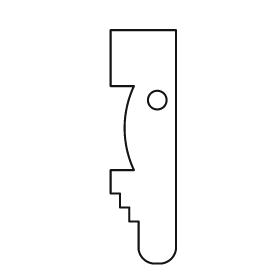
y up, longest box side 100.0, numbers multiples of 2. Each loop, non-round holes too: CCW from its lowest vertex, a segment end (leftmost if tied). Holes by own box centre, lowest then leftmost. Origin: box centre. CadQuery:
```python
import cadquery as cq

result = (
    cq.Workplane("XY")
    .moveTo(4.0, -50.0)
    .lineTo(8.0, -50.0)
    .threePointArc((12.0, -48.0), (14.0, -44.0))
    .lineTo(14.0, 50.0)
    .lineTo(-14.0, 50.0)
    .lineTo(-14.0, 26.0)
    .lineTo(-4.0, 26.0)
    .threePointArc((-8.0, 8.0), (-4.0, -10.0))
    .lineTo(-14.0, -10.0)
    .lineTo(-14.0, -20.0)
    .lineTo(-10.0, -20.0)
    .lineTo(-10.0, -26.0)
    .lineTo(-6.0, -26.0)
    .lineTo(-6.0, -32.0)
    .lineTo(-2.0, -32.0)
    .lineTo(-2.0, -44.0)
    .threePointArc((0.0, -48.0), (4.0, -50.0))
    .close()
    .moveTo(6.0, 20.0)
    .circle(4.0)
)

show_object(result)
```